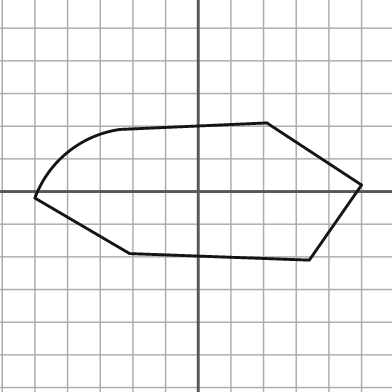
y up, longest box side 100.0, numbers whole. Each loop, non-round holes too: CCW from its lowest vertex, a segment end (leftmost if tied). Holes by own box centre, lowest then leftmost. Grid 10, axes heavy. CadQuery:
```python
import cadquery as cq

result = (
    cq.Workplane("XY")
    .moveTo(34.0, -21.0)
    .lineTo(50.0, 2.0)
    .lineTo(21.0, 21.0)
    .lineTo(-24.0, 19.0)
    .threePointArc((-40.0, 12.0), (-50.0, -2.0))
    .lineTo(-21.0, -19.0)
    .close()
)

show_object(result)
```